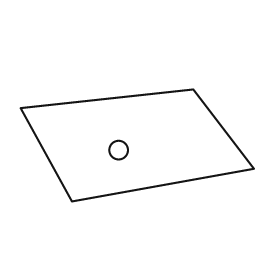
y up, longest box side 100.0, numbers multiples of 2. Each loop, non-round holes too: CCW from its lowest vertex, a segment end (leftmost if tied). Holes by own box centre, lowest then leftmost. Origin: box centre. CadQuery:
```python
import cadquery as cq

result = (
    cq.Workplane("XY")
    .moveTo(-28.0, -24.0)
    .lineTo(50.0, -10.0)
    .lineTo(24.0, 24.0)
    .lineTo(-50.0, 16.0)
    .close()
    .moveTo(-8.0, -2.0)
    .circle(4.0)
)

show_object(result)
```